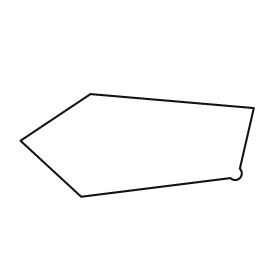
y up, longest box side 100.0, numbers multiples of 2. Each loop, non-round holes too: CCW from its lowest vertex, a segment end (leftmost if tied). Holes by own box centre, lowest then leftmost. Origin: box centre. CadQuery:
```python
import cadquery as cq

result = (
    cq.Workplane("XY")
    .moveTo(-24.0, -22.0)
    .lineTo(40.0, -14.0)
    .threePointArc((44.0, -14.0), (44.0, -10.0))
    .lineTo(50.0, 16.0)
    .lineTo(-20.0, 22.0)
    .lineTo(-50.0, 2.0)
    .close()
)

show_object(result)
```